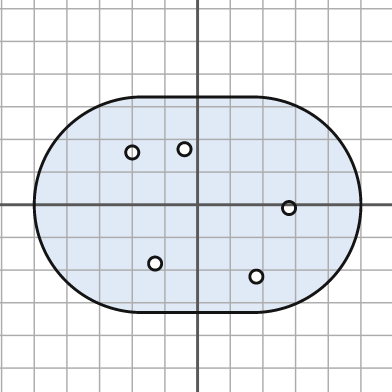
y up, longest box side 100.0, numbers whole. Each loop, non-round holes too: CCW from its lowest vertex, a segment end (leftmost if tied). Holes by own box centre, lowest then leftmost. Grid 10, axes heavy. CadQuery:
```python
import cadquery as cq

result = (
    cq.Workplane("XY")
    .moveTo(-17.0, -33.0)
    .lineTo(17.0, -33.0)
    .threePointArc((50.0, 0.0), (17.0, 33.0))
    .lineTo(-17.0, 33.0)
    .threePointArc((-50.0, 0.0), (-17.0, -33.0))
    .close()
    .moveTo(18.0, -22.0)
    .circle(2.0)
    .moveTo(-13.0, -18.0)
    .circle(2.0)
    .moveTo(28.0, -1.0)
    .circle(2.0)
    .moveTo(-20.0, 16.0)
    .circle(2.0)
    .moveTo(-4.0, 17.0)
    .circle(2.0)
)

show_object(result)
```